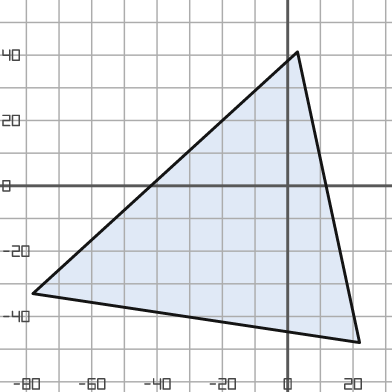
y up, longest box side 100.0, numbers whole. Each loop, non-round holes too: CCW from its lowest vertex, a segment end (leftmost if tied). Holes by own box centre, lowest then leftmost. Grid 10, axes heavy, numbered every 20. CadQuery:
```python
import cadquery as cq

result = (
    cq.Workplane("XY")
    .moveTo(22.0, -48.0)
    .lineTo(3.0, 41.0)
    .lineTo(-78.0, -33.0)
    .close()
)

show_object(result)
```